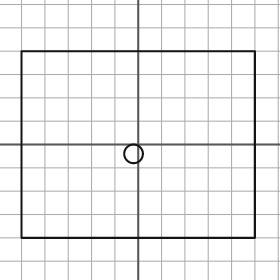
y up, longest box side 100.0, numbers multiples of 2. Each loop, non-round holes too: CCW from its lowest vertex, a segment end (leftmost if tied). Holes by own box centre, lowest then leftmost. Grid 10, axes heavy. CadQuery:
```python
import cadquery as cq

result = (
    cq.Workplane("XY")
    .moveTo(-50.0, -40.0)
    .lineTo(50.0, -40.0)
    .lineTo(50.0, 40.0)
    .lineTo(-50.0, 40.0)
    .close()
    .moveTo(-2.0, -4.0)
    .circle(4.0)
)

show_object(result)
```